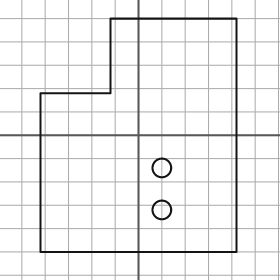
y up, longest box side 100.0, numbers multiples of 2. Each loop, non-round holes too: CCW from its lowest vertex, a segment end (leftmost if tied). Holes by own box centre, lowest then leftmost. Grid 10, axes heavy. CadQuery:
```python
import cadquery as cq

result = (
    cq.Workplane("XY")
    .moveTo(-42.0, -50.0)
    .lineTo(42.0, -50.0)
    .lineTo(42.0, 50.0)
    .lineTo(-12.0, 50.0)
    .lineTo(-12.0, 18.0)
    .lineTo(-42.0, 18.0)
    .close()
    .moveTo(10.0, -32.0)
    .circle(4.0)
    .moveTo(10.0, -14.0)
    .circle(4.0)
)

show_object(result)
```